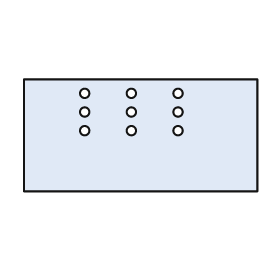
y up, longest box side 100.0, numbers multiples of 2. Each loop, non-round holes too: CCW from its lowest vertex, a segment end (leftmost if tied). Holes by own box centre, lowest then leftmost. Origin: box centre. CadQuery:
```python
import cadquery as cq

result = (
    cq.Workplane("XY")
    .moveTo(-50.0, -24.0)
    .lineTo(50.0, -24.0)
    .lineTo(50.0, 24.0)
    .lineTo(-50.0, 24.0)
    .close()
    .moveTo(-24.0, 2.0)
    .circle(2.0)
    .moveTo(-4.0, 2.0)
    .circle(2.0)
    .moveTo(16.0, 2.0)
    .circle(2.0)
    .moveTo(-24.0, 10.0)
    .circle(2.0)
    .moveTo(-4.0, 10.0)
    .circle(2.0)
    .moveTo(16.0, 10.0)
    .circle(2.0)
    .moveTo(-24.0, 18.0)
    .circle(2.0)
    .moveTo(-4.0, 18.0)
    .circle(2.0)
    .moveTo(16.0, 18.0)
    .circle(2.0)
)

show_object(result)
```